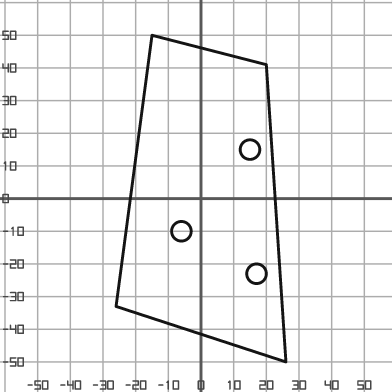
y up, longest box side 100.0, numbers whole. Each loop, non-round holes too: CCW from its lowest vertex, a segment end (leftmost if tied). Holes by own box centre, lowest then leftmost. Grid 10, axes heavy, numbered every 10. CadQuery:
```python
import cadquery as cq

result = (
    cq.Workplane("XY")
    .moveTo(26.0, -50.0)
    .lineTo(20.0, 41.0)
    .lineTo(-15.0, 50.0)
    .lineTo(-26.0, -33.0)
    .close()
    .moveTo(17.0, -23.0)
    .circle(3.0)
    .moveTo(-6.0, -10.0)
    .circle(3.0)
    .moveTo(15.0, 15.0)
    .circle(3.0)
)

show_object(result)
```